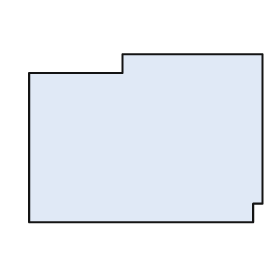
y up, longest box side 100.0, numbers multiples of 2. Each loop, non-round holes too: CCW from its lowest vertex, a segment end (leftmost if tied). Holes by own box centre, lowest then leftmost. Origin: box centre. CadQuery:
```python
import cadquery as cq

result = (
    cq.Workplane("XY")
    .moveTo(-50.0, -36.0)
    .lineTo(46.0, -36.0)
    .lineTo(46.0, -28.0)
    .lineTo(50.0, -28.0)
    .lineTo(50.0, 36.0)
    .lineTo(-10.0, 36.0)
    .lineTo(-10.0, 28.0)
    .lineTo(-50.0, 28.0)
    .close()
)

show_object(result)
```